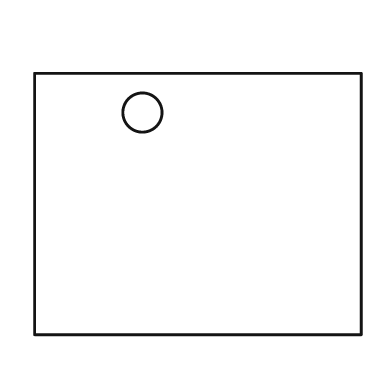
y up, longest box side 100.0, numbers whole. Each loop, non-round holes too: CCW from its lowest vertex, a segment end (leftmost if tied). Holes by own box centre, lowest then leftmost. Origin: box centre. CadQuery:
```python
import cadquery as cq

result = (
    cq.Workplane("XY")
    .moveTo(-50.0, -40.0)
    .lineTo(50.0, -40.0)
    .lineTo(50.0, 40.0)
    .lineTo(-50.0, 40.0)
    .close()
    .moveTo(-17.0, 28.0)
    .circle(6.0)
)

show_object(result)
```